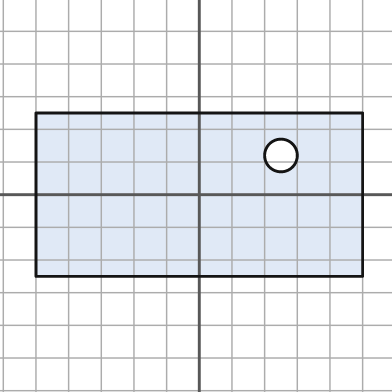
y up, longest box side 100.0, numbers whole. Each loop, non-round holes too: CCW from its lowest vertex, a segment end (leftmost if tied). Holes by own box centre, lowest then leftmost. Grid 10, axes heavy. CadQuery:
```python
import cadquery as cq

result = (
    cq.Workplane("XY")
    .moveTo(-50.0, -25.0)
    .lineTo(50.0, -25.0)
    .lineTo(50.0, 25.0)
    .lineTo(-50.0, 25.0)
    .close()
    .moveTo(25.0, 12.0)
    .circle(5.0)
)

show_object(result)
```